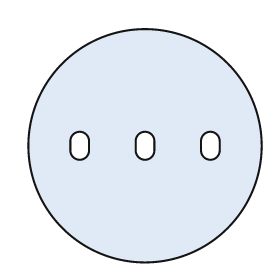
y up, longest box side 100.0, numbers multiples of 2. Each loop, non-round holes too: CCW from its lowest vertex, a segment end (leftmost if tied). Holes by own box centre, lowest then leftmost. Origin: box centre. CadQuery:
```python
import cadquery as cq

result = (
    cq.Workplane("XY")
    .moveTo(0.0, 0.0)
    .circle(50.0)
    .moveTo(-32.0, -2.0)
    .threePointArc((-28.0, -6.0), (-24.0, -2.0))
    .lineTo(-24.0, 2.0)
    .threePointArc((-28.0, 6.0), (-32.0, 2.0))
    .close()
    .moveTo(-4.0, -2.0)
    .threePointArc((0.0, -6.0), (4.0, -2.0))
    .lineTo(4.0, 2.0)
    .threePointArc((0.0, 6.0), (-4.0, 2.0))
    .close()
    .moveTo(24.0, -2.0)
    .threePointArc((28.0, -6.0), (32.0, -2.0))
    .lineTo(32.0, 2.0)
    .threePointArc((28.0, 6.0), (24.0, 2.0))
    .close()
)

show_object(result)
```